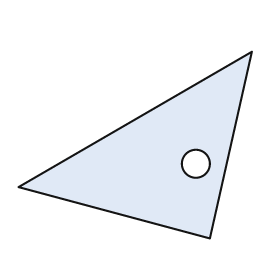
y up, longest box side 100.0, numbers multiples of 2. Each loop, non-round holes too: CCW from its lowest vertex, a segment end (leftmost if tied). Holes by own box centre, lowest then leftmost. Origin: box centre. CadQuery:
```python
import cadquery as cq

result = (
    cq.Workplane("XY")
    .moveTo(32.0, -40.0)
    .lineTo(50.0, 40.0)
    .lineTo(-50.0, -18.0)
    .close()
    .moveTo(26.0, -8.0)
    .circle(6.0)
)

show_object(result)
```